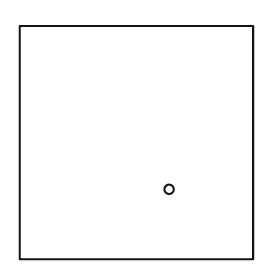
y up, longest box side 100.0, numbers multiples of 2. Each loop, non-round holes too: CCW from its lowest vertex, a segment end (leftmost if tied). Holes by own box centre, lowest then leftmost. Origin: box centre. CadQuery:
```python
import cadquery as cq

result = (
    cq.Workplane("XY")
    .moveTo(-50.0, -50.0)
    .lineTo(50.0, -50.0)
    .lineTo(50.0, 50.0)
    .lineTo(-50.0, 50.0)
    .close()
    .moveTo(14.0, -20.0)
    .circle(2.0)
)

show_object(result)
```